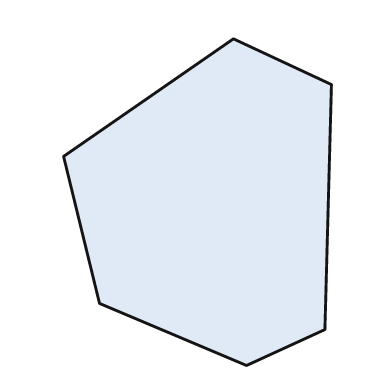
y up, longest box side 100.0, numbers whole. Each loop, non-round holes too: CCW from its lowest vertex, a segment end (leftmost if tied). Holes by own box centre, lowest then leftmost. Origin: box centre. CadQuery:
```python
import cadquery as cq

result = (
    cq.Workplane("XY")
    .moveTo(15.0, -50.0)
    .lineTo(39.0, -39.0)
    .lineTo(41.0, 36.0)
    .lineTo(11.0, 50.0)
    .lineTo(-41.0, 14.0)
    .lineTo(-30.0, -31.0)
    .close()
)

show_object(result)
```